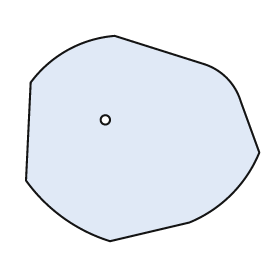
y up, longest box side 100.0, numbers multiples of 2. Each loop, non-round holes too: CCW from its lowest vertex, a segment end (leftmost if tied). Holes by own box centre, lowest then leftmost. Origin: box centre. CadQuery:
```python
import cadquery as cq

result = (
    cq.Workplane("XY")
    .moveTo(-14.0, -44.0)
    .lineTo(20.0, -36.0)
    .threePointArc((38.0, -24.0), (50.0, -6.0))
    .lineTo(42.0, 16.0)
    .threePointArc((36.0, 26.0), (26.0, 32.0))
    .lineTo(-12.0, 44.0)
    .threePointArc((-32.0, 38.0), (-48.0, 24.0))
    .lineTo(-50.0, -18.0)
    .threePointArc((-34.0, -34.0), (-14.0, -44.0))
    .close()
    .moveTo(-16.0, 8.0)
    .circle(2.0)
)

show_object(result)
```